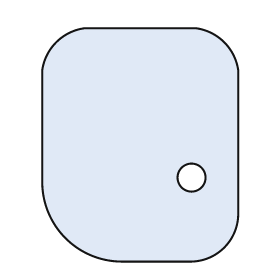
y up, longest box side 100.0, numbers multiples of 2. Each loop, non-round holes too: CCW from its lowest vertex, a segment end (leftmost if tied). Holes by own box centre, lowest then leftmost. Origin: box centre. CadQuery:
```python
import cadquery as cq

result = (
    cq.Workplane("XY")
    .moveTo(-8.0, -50.0)
    .lineTo(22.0, -50.0)
    .threePointArc((36.0, -44.0), (42.0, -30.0))
    .lineTo(42.0, 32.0)
    .threePointArc((36.0, 44.0), (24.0, 50.0))
    .lineTo(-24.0, 50.0)
    .threePointArc((-36.0, 44.0), (-42.0, 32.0))
    .lineTo(-42.0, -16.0)
    .threePointArc((-32.0, -40.0), (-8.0, -50.0))
    .close()
    .moveTo(22.0, -14.0)
    .circle(6.0)
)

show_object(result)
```